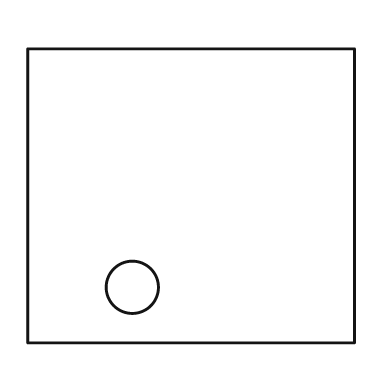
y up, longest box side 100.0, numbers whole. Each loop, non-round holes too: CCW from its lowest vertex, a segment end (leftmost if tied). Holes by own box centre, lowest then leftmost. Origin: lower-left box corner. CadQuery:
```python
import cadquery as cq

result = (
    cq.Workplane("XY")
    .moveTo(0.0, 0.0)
    .lineTo(100.0, 0.0)
    .lineTo(100.0, 90.0)
    .lineTo(0.0, 90.0)
    .close()
    .moveTo(32.0, 17.0)
    .circle(8.0)
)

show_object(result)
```